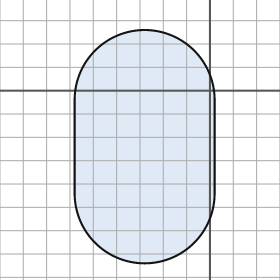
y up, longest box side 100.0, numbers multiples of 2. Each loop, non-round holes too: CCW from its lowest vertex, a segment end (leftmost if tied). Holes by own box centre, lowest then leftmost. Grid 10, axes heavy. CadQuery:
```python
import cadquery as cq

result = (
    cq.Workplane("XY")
    .moveTo(-58.0, -44.0)
    .threePointArc((-28.0, -74.0), (2.0, -44.0))
    .lineTo(2.0, -4.0)
    .threePointArc((-28.0, 26.0), (-58.0, -4.0))
    .close()
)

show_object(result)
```